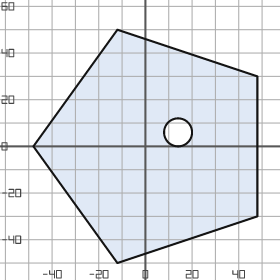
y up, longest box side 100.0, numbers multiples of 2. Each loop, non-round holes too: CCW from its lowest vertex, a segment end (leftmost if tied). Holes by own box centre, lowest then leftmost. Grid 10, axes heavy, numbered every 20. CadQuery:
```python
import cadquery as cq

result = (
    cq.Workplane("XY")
    .moveTo(-12.0, -50.0)
    .lineTo(48.0, -30.0)
    .lineTo(48.0, 30.0)
    .lineTo(-12.0, 50.0)
    .lineTo(-48.0, 0.0)
    .close()
    .moveTo(14.0, 6.0)
    .circle(6.0)
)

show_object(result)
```